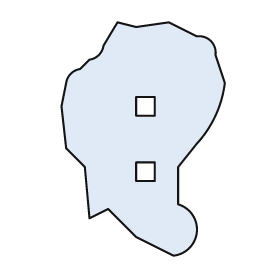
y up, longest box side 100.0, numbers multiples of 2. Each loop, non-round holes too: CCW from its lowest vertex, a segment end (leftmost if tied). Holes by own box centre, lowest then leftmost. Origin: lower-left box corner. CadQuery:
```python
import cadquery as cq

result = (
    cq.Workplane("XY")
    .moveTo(48.0, 0.0)
    .threePointArc((58.0, 10.0), (50.0, 22.0))
    .lineTo(50.0, 38.0)
    .lineTo(58.0, 48.0)
    .threePointArc((66.0, 60.0), (70.0, 74.0))
    .lineTo(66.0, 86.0)
    .threePointArc((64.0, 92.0), (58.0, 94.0))
    .lineTo(46.0, 100.0)
    .lineTo(32.0, 98.0)
    .lineTo(24.0, 100.0)
    .lineTo(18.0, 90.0)
    .threePointArc((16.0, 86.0), (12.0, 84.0))
    .lineTo(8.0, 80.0)
    .threePointArc((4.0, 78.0), (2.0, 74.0))
    .lineTo(0.0, 64.0)
    .lineTo(2.0, 46.0)
    .lineTo(10.0, 38.0)
    .lineTo(12.0, 16.0)
    .lineTo(20.0, 20.0)
    .lineTo(32.0, 8.0)
    .close()
    .moveTo(32.0, 32.0)
    .lineTo(40.0, 32.0)
    .lineTo(40.0, 40.0)
    .lineTo(32.0, 40.0)
    .close()
    .moveTo(32.0, 60.0)
    .lineTo(40.0, 60.0)
    .lineTo(40.0, 68.0)
    .lineTo(32.0, 68.0)
    .close()
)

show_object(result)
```